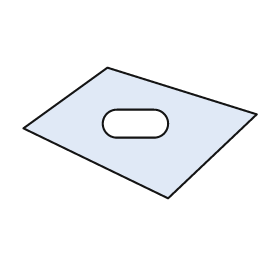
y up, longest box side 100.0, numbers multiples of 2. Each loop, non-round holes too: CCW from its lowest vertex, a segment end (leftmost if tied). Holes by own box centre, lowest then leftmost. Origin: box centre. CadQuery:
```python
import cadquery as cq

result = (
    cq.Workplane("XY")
    .moveTo(12.0, -28.0)
    .lineTo(50.0, 8.0)
    .lineTo(-14.0, 28.0)
    .lineTo(-50.0, 2.0)
    .close()
    .moveTo(-10.0, -2.0)
    .lineTo(6.0, -2.0)
    .threePointArc((12.0, 4.0), (6.0, 10.0))
    .lineTo(-10.0, 10.0)
    .threePointArc((-16.0, 4.0), (-10.0, -2.0))
    .close()
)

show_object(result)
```